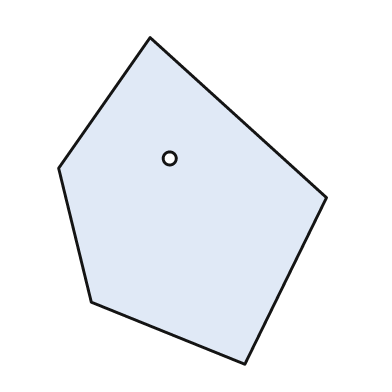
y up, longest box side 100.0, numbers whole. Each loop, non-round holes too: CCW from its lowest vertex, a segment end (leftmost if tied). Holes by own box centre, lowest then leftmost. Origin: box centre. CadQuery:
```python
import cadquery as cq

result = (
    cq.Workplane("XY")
    .moveTo(16.0, -50.0)
    .lineTo(41.0, 1.0)
    .lineTo(-13.0, 50.0)
    .lineTo(-41.0, 10.0)
    .lineTo(-31.0, -31.0)
    .close()
    .moveTo(-7.0, 13.0)
    .circle(2.0)
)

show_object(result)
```